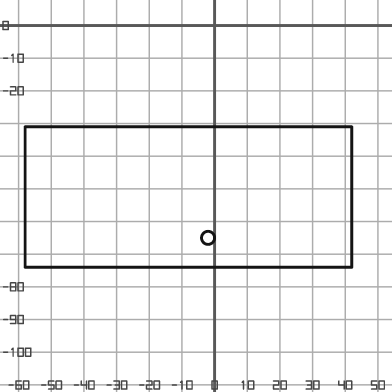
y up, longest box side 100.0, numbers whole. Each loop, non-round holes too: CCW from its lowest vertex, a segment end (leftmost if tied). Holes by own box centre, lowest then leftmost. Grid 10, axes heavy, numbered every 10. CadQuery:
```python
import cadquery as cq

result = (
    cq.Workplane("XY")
    .moveTo(-58.0, -74.0)
    .lineTo(42.0, -74.0)
    .lineTo(42.0, -31.0)
    .lineTo(-58.0, -31.0)
    .close()
    .moveTo(-2.0, -65.0)
    .circle(2.0)
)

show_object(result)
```